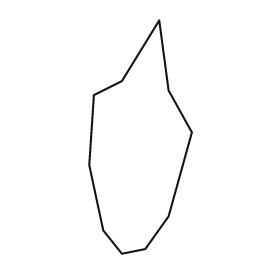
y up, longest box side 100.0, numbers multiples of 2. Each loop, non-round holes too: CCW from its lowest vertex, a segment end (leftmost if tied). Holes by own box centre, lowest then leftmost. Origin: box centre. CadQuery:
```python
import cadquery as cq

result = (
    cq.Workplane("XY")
    .moveTo(-8.0, -50.0)
    .lineTo(2.0, -48.0)
    .lineTo(12.0, -34.0)
    .lineTo(22.0, 2.0)
    .lineTo(12.0, 20.0)
    .lineTo(8.0, 50.0)
    .lineTo(-8.0, 24.0)
    .lineTo(-20.0, 18.0)
    .lineTo(-22.0, -12.0)
    .lineTo(-16.0, -40.0)
    .close()
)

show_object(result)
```